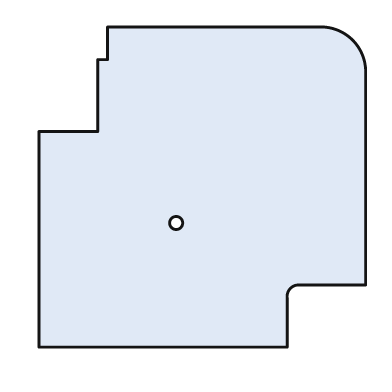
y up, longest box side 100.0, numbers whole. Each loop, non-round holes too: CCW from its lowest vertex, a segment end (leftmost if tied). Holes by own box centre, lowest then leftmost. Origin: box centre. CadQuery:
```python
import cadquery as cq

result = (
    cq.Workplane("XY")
    .moveTo(-50.0, -49.0)
    .lineTo(26.0, -49.0)
    .lineTo(26.0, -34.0)
    .threePointArc((27.0, -31.0), (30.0, -30.0))
    .lineTo(50.0, -30.0)
    .lineTo(50.0, 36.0)
    .threePointArc((46.0, 45.0), (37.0, 49.0))
    .lineTo(-29.0, 49.0)
    .lineTo(-29.0, 39.0)
    .lineTo(-32.0, 39.0)
    .lineTo(-32.0, 17.0)
    .lineTo(-50.0, 17.0)
    .close()
    .moveTo(-8.0, -11.0)
    .circle(2.0)
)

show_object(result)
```